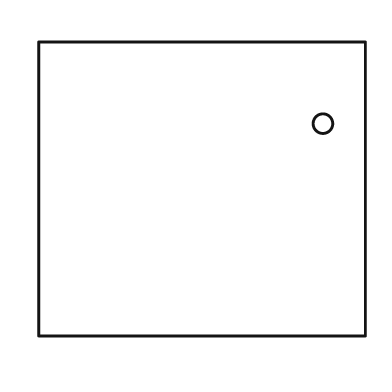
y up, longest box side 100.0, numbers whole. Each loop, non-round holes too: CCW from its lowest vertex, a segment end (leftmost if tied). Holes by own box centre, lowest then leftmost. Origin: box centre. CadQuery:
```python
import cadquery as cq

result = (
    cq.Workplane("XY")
    .moveTo(-50.0, -45.0)
    .lineTo(50.0, -45.0)
    .lineTo(50.0, 45.0)
    .lineTo(-50.0, 45.0)
    .close()
    .moveTo(37.0, 20.0)
    .circle(3.0)
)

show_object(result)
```